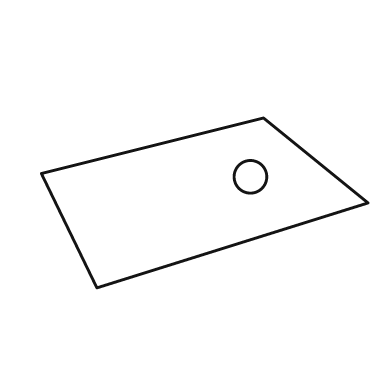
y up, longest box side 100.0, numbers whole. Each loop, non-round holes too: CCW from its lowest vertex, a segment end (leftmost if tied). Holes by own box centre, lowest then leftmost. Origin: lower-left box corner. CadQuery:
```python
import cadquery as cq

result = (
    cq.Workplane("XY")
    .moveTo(17.0, 0.0)
    .lineTo(100.0, 26.0)
    .lineTo(68.0, 52.0)
    .lineTo(0.0, 35.0)
    .close()
    .moveTo(64.0, 34.0)
    .circle(5.0)
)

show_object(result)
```